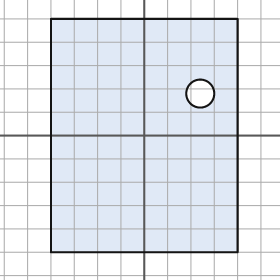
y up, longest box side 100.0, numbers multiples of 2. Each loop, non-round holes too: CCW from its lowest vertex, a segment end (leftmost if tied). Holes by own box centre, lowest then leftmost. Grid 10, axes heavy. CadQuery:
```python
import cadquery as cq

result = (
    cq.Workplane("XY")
    .moveTo(-40.0, -50.0)
    .lineTo(40.0, -50.0)
    .lineTo(40.0, 50.0)
    .lineTo(-40.0, 50.0)
    .close()
    .moveTo(24.0, 18.0)
    .circle(6.0)
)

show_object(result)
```